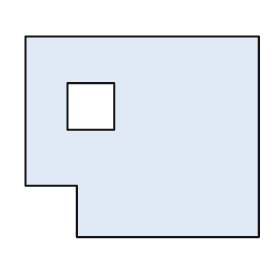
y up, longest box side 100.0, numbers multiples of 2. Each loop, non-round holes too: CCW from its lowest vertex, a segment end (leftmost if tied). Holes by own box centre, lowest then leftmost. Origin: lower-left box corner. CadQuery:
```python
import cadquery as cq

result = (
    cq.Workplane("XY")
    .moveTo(22.0, 0.0)
    .lineTo(100.0, 0.0)
    .lineTo(100.0, 86.0)
    .lineTo(0.0, 86.0)
    .lineTo(0.0, 22.0)
    .lineTo(22.0, 22.0)
    .close()
    .moveTo(18.0, 46.0)
    .lineTo(38.0, 46.0)
    .lineTo(38.0, 66.0)
    .lineTo(18.0, 66.0)
    .close()
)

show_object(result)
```